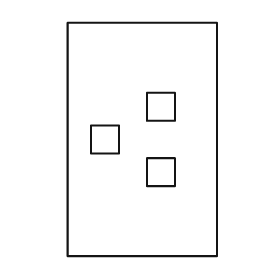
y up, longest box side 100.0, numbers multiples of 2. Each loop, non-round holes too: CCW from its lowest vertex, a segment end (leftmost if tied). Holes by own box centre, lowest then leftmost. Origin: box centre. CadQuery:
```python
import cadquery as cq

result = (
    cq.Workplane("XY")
    .moveTo(-32.0, -50.0)
    .lineTo(32.0, -50.0)
    .lineTo(32.0, 50.0)
    .lineTo(-32.0, 50.0)
    .close()
    .moveTo(2.0, -20.0)
    .lineTo(14.0, -20.0)
    .lineTo(14.0, -8.0)
    .lineTo(2.0, -8.0)
    .close()
    .moveTo(-22.0, -6.0)
    .lineTo(-10.0, -6.0)
    .lineTo(-10.0, 6.0)
    .lineTo(-22.0, 6.0)
    .close()
    .moveTo(2.0, 8.0)
    .lineTo(14.0, 8.0)
    .lineTo(14.0, 20.0)
    .lineTo(2.0, 20.0)
    .close()
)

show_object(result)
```